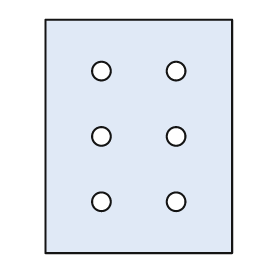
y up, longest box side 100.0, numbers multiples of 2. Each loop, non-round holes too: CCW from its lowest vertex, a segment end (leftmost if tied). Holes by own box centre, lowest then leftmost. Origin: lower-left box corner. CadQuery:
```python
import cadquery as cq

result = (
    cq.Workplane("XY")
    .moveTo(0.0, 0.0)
    .lineTo(80.0, 0.0)
    .lineTo(80.0, 100.0)
    .lineTo(0.0, 100.0)
    .close()
    .moveTo(24.0, 22.0)
    .circle(4.0)
    .moveTo(56.0, 22.0)
    .circle(4.0)
    .moveTo(24.0, 50.0)
    .circle(4.0)
    .moveTo(56.0, 50.0)
    .circle(4.0)
    .moveTo(24.0, 78.0)
    .circle(4.0)
    .moveTo(56.0, 78.0)
    .circle(4.0)
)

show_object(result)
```